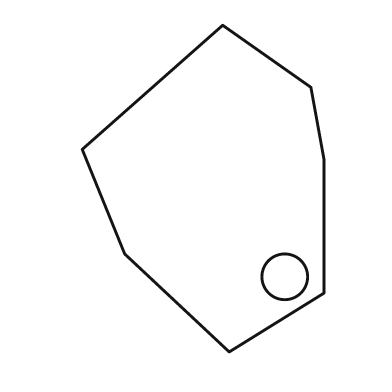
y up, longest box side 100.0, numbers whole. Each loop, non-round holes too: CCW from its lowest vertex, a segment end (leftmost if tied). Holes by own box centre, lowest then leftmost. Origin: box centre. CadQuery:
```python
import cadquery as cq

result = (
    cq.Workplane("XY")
    .moveTo(8.0, -50.0)
    .lineTo(37.0, -32.0)
    .lineTo(37.0, 9.0)
    .lineTo(33.0, 31.0)
    .lineTo(6.0, 50.0)
    .lineTo(-37.0, 12.0)
    .lineTo(-24.0, -20.0)
    .close()
    .moveTo(25.0, -27.0)
    .circle(7.0)
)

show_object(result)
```